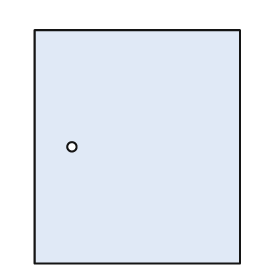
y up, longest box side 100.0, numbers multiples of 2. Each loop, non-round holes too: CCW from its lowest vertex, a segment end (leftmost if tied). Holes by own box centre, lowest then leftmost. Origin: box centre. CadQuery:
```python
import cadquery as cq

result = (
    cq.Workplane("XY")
    .moveTo(-44.0, -50.0)
    .lineTo(44.0, -50.0)
    .lineTo(44.0, 50.0)
    .lineTo(-44.0, 50.0)
    .close()
    .moveTo(-28.0, 0.0)
    .circle(2.0)
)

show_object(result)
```